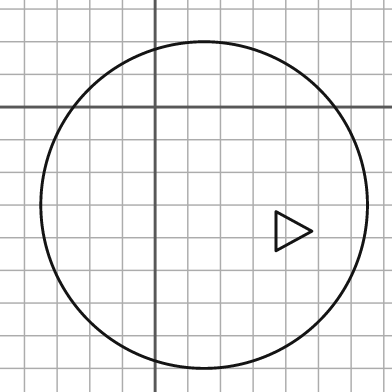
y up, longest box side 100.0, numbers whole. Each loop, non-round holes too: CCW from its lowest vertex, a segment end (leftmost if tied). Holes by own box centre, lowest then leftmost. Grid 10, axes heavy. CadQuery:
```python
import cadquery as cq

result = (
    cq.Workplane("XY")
    .moveTo(15.0, -30.0)
    .circle(50.0)
    .moveTo(37.0, -44.0)
    .lineTo(48.0, -38.0)
    .lineTo(37.0, -32.0)
    .close()
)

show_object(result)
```